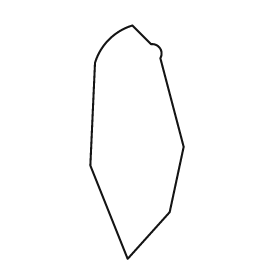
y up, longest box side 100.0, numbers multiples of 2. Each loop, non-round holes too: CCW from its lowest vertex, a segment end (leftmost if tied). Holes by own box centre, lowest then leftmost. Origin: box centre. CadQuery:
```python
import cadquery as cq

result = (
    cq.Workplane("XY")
    .moveTo(-4.0, -50.0)
    .lineTo(14.0, -30.0)
    .lineTo(20.0, -2.0)
    .lineTo(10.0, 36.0)
    .threePointArc((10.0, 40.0), (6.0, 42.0))
    .lineTo(-2.0, 50.0)
    .threePointArc((-12.0, 44.0), (-18.0, 34.0))
    .lineTo(-20.0, -10.0)
    .close()
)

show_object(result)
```